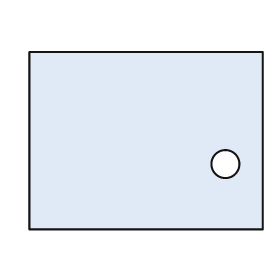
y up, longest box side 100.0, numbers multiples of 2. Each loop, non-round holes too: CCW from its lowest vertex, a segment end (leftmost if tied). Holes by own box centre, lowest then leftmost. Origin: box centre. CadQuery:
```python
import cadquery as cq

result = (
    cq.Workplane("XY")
    .moveTo(-50.0, -38.0)
    .lineTo(50.0, -38.0)
    .lineTo(50.0, 38.0)
    .lineTo(-50.0, 38.0)
    .close()
    .moveTo(34.0, -10.0)
    .circle(6.0)
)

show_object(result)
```